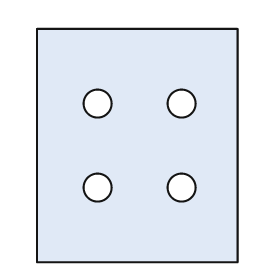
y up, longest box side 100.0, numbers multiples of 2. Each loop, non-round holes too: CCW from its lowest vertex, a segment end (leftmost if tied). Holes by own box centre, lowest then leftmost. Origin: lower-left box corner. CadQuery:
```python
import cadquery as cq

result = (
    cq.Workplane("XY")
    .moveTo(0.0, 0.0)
    .lineTo(86.0, 0.0)
    .lineTo(86.0, 100.0)
    .lineTo(0.0, 100.0)
    .close()
    .moveTo(26.0, 32.0)
    .circle(6.0)
    .moveTo(62.0, 32.0)
    .circle(6.0)
    .moveTo(26.0, 68.0)
    .circle(6.0)
    .moveTo(62.0, 68.0)
    .circle(6.0)
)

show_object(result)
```